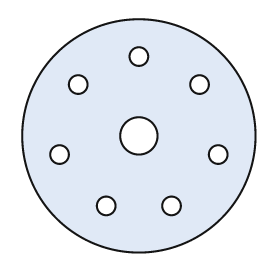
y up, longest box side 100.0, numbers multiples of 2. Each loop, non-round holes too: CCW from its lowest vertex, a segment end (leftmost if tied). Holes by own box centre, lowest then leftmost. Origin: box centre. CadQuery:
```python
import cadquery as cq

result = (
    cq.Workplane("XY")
    .moveTo(0.0, 0.0)
    .circle(50.0)
    .moveTo(-14.0, -30.0)
    .circle(4.0)
    .moveTo(14.0, -30.0)
    .circle(4.0)
    .moveTo(-34.0, -8.0)
    .circle(4.0)
    .moveTo(34.0, -8.0)
    .circle(4.0)
    .moveTo(0.0, 0.0)
    .circle(8.0)
    .moveTo(-26.0, 22.0)
    .circle(4.0)
    .moveTo(26.0, 22.0)
    .circle(4.0)
    .moveTo(0.0, 34.0)
    .circle(4.0)
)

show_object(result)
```